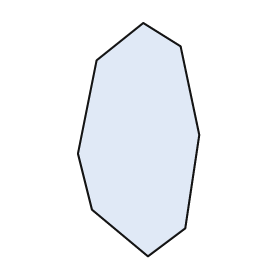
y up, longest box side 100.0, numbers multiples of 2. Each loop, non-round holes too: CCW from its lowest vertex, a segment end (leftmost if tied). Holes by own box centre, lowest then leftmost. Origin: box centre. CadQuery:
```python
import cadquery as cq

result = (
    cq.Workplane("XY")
    .moveTo(4.0, -50.0)
    .lineTo(20.0, -38.0)
    .lineTo(26.0, 2.0)
    .lineTo(18.0, 40.0)
    .lineTo(2.0, 50.0)
    .lineTo(-18.0, 34.0)
    .lineTo(-26.0, -6.0)
    .lineTo(-20.0, -30.0)
    .close()
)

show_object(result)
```